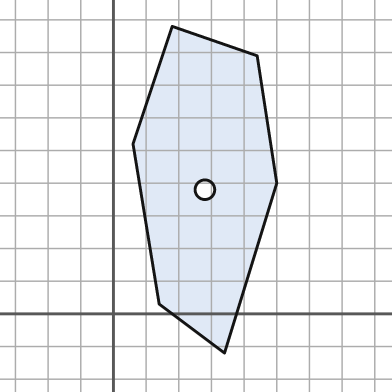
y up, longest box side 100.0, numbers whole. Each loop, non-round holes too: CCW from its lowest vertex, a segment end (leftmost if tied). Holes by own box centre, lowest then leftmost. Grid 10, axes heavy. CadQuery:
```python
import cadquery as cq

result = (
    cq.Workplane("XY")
    .moveTo(34.0, -12.0)
    .lineTo(50.0, 40.0)
    .lineTo(44.0, 79.0)
    .lineTo(18.0, 88.0)
    .lineTo(6.0, 52.0)
    .lineTo(14.0, 3.0)
    .close()
    .moveTo(28.0, 38.0)
    .circle(3.0)
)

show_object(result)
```